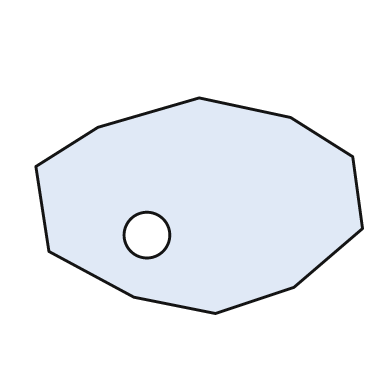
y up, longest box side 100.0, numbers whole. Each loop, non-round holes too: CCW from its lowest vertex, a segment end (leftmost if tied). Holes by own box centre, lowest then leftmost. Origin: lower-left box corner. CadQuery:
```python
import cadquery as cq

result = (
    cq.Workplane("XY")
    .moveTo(55.0, 0.0)
    .lineTo(79.0, 8.0)
    .lineTo(100.0, 26.0)
    .lineTo(97.0, 48.0)
    .lineTo(78.0, 60.0)
    .lineTo(50.0, 66.0)
    .lineTo(19.0, 57.0)
    .lineTo(0.0, 45.0)
    .lineTo(4.0, 19.0)
    .lineTo(30.0, 5.0)
    .close()
    .moveTo(34.0, 24.0)
    .circle(7.0)
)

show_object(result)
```